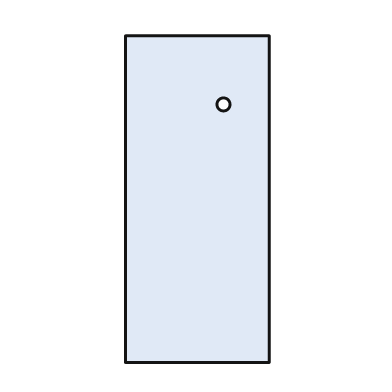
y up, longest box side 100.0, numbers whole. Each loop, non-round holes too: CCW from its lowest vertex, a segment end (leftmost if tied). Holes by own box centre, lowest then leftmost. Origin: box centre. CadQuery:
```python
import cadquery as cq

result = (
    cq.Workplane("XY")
    .moveTo(-22.0, -50.0)
    .lineTo(22.0, -50.0)
    .lineTo(22.0, 50.0)
    .lineTo(-22.0, 50.0)
    .close()
    .moveTo(8.0, 29.0)
    .circle(2.0)
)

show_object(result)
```